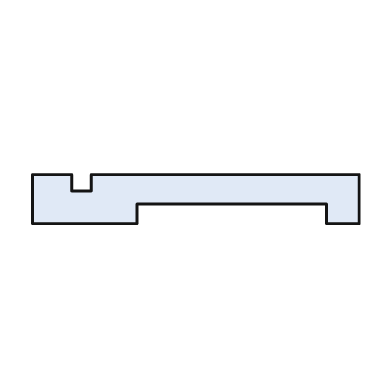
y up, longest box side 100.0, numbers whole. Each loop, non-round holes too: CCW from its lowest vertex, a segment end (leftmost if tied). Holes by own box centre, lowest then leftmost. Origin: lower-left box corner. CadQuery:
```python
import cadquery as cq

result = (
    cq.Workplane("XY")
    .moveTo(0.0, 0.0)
    .lineTo(32.0, 0.0)
    .lineTo(32.0, 6.0)
    .lineTo(90.0, 6.0)
    .lineTo(90.0, 0.0)
    .lineTo(100.0, 0.0)
    .lineTo(100.0, 15.0)
    .lineTo(18.0, 15.0)
    .lineTo(18.0, 10.0)
    .lineTo(12.0, 10.0)
    .lineTo(12.0, 15.0)
    .lineTo(0.0, 15.0)
    .close()
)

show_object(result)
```